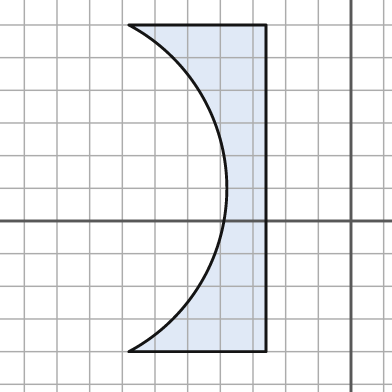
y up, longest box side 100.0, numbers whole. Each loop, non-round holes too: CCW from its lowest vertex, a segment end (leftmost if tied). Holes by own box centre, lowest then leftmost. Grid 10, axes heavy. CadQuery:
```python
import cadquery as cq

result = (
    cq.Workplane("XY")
    .moveTo(-68.0, -40.0)
    .lineTo(-26.0, -40.0)
    .lineTo(-26.0, 60.0)
    .lineTo(-68.0, 60.0)
    .threePointArc((-38.0, 10.0), (-68.0, -40.0))
    .close()
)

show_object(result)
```